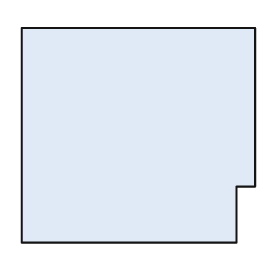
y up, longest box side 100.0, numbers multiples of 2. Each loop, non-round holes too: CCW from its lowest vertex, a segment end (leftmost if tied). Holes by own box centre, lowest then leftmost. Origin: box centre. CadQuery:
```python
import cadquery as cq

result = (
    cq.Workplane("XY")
    .moveTo(-50.0, -46.0)
    .lineTo(42.0, -46.0)
    .lineTo(42.0, -22.0)
    .lineTo(50.0, -22.0)
    .lineTo(50.0, 46.0)
    .lineTo(-50.0, 46.0)
    .close()
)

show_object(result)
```